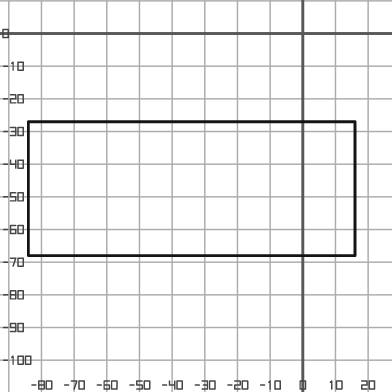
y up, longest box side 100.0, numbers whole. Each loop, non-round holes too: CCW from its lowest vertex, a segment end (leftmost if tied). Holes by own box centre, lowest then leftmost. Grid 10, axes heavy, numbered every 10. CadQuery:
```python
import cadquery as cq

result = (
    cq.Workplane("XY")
    .moveTo(-84.0, -68.0)
    .lineTo(16.0, -68.0)
    .lineTo(16.0, -27.0)
    .lineTo(-84.0, -27.0)
    .close()
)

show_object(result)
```